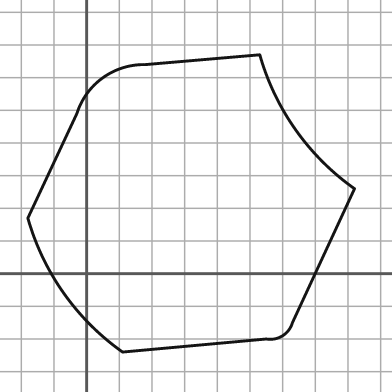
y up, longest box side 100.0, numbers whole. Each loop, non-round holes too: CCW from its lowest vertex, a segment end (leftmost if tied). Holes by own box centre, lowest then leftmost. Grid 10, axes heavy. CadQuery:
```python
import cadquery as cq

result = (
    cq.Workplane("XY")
    .moveTo(11.0, -24.0)
    .lineTo(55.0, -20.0)
    .threePointArc((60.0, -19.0), (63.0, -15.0))
    .lineTo(82.0, 26.0)
    .threePointArc((64.0, 44.0), (53.0, 67.0))
    .lineTo(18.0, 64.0)
    .threePointArc((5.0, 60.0), (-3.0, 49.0))
    .lineTo(-18.0, 17.0)
    .threePointArc((-7.0, -6.0), (11.0, -24.0))
    .close()
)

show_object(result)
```